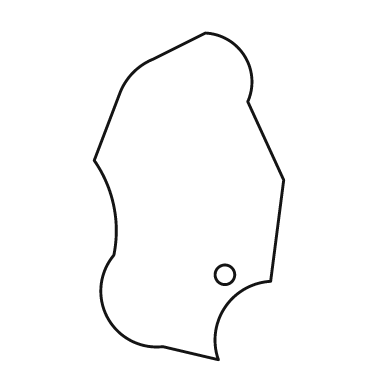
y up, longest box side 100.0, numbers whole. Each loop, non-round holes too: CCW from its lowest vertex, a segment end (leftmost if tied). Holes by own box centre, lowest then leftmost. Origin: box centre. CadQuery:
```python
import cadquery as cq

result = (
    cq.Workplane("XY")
    .moveTo(9.0, -50.0)
    .threePointArc((11.0, -34.0), (25.0, -26.0))
    .lineTo(29.0, 5.0)
    .lineTo(18.0, 29.0)
    .threePointArc((17.0, 43.0), (5.0, 50.0))
    .lineTo(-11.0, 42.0)
    .threePointArc((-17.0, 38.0), (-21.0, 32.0))
    .lineTo(-29.0, 11.0)
    .threePointArc((-23.0, -3.0), (-23.0, -18.0))
    .threePointArc((-25.0, -37.0), (-8.0, -46.0))
    .close()
    .moveTo(11.0, -24.0)
    .circle(3.0)
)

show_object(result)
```